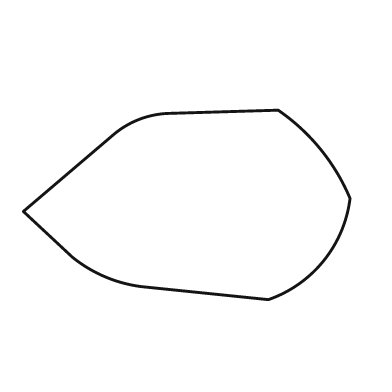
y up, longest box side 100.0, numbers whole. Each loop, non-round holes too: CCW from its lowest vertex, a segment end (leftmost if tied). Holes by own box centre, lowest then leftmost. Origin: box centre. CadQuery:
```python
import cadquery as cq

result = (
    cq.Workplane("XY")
    .moveTo(25.0, -29.0)
    .threePointArc((42.0, -17.0), (50.0, 2.0))
    .threePointArc((41.0, 17.0), (28.0, 29.0))
    .lineTo(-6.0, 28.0)
    .threePointArc((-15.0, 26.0), (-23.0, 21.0))
    .lineTo(-50.0, -2.0)
    .lineTo(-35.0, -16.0)
    .threePointArc((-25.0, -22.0), (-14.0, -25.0))
    .close()
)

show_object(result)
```